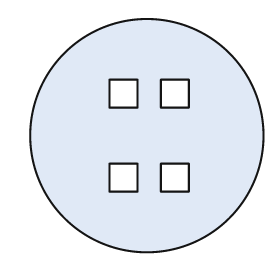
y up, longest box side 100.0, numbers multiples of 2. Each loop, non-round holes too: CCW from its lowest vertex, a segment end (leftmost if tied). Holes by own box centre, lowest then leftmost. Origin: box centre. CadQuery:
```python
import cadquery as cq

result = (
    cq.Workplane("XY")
    .moveTo(0.0, 0.0)
    .circle(50.0)
    .moveTo(-16.0, -24.0)
    .lineTo(-4.0, -24.0)
    .lineTo(-4.0, -12.0)
    .lineTo(-16.0, -12.0)
    .close()
    .moveTo(6.0, -24.0)
    .lineTo(18.0, -24.0)
    .lineTo(18.0, -12.0)
    .lineTo(6.0, -12.0)
    .close()
    .moveTo(-16.0, 12.0)
    .lineTo(-4.0, 12.0)
    .lineTo(-4.0, 24.0)
    .lineTo(-16.0, 24.0)
    .close()
    .moveTo(6.0, 12.0)
    .lineTo(18.0, 12.0)
    .lineTo(18.0, 24.0)
    .lineTo(6.0, 24.0)
    .close()
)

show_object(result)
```